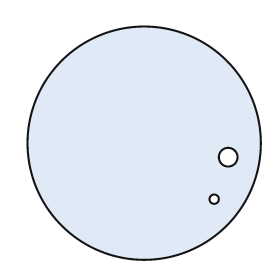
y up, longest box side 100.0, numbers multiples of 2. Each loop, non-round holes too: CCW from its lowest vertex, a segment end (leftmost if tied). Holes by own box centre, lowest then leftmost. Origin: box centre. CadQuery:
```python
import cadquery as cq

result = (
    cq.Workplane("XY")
    .moveTo(0.0, 0.0)
    .circle(50.0)
    .moveTo(30.0, -24.0)
    .circle(2.0)
    .moveTo(36.0, -6.0)
    .circle(4.0)
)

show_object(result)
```